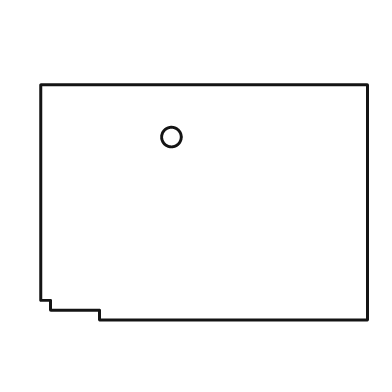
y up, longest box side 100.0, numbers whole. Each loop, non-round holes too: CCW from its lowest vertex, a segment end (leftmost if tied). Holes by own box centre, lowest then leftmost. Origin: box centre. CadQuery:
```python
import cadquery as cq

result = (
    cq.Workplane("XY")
    .moveTo(-32.0, -36.0)
    .lineTo(50.0, -36.0)
    .lineTo(50.0, 36.0)
    .lineTo(-50.0, 36.0)
    .lineTo(-50.0, -30.0)
    .lineTo(-47.0, -30.0)
    .lineTo(-47.0, -33.0)
    .lineTo(-32.0, -33.0)
    .close()
    .moveTo(-10.0, 20.0)
    .circle(3.0)
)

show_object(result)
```